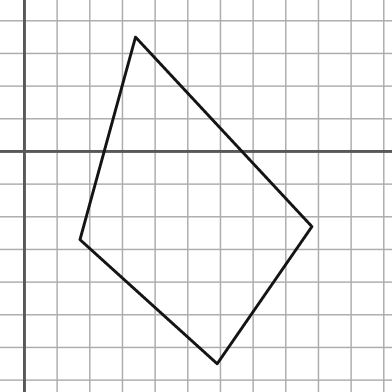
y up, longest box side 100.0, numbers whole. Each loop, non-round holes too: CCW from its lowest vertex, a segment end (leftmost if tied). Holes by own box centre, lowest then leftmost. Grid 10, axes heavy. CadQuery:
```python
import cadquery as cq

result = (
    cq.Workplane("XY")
    .moveTo(59.0, -65.0)
    .lineTo(88.0, -23.0)
    .lineTo(34.0, 35.0)
    .lineTo(17.0, -27.0)
    .close()
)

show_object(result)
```